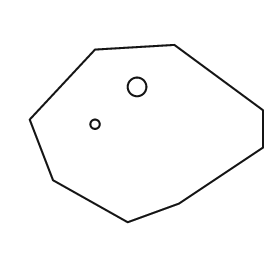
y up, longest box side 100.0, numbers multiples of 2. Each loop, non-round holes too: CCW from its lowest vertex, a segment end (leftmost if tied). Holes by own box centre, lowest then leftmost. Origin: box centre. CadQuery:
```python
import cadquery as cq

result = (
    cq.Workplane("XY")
    .moveTo(-8.0, -38.0)
    .lineTo(14.0, -30.0)
    .lineTo(50.0, -6.0)
    .lineTo(50.0, 10.0)
    .lineTo(12.0, 38.0)
    .lineTo(-22.0, 36.0)
    .lineTo(-50.0, 6.0)
    .lineTo(-40.0, -20.0)
    .close()
    .moveTo(-22.0, 4.0)
    .circle(2.0)
    .moveTo(-4.0, 20.0)
    .circle(4.0)
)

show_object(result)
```